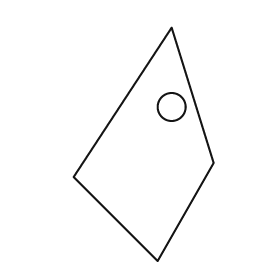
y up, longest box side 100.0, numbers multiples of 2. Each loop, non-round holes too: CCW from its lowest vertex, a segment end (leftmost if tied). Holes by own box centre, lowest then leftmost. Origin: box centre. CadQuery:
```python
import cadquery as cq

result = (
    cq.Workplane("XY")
    .moveTo(6.0, -50.0)
    .lineTo(30.0, -8.0)
    .lineTo(12.0, 50.0)
    .lineTo(-30.0, -14.0)
    .close()
    .moveTo(12.0, 16.0)
    .circle(6.0)
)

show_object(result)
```